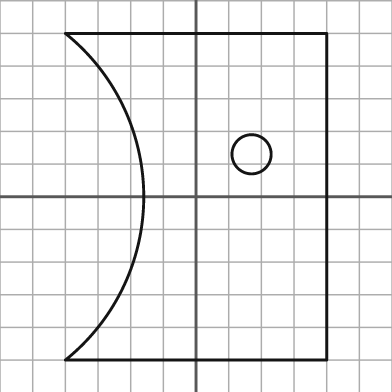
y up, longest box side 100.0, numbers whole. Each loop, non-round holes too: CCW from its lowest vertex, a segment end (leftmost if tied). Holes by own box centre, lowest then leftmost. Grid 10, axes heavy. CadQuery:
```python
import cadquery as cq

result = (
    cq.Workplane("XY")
    .moveTo(-40.0, -50.0)
    .lineTo(40.0, -50.0)
    .lineTo(40.0, 50.0)
    .lineTo(-40.0, 50.0)
    .threePointArc((-16.0, 0.0), (-40.0, -50.0))
    .close()
    .moveTo(17.0, 13.0)
    .circle(6.0)
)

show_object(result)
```